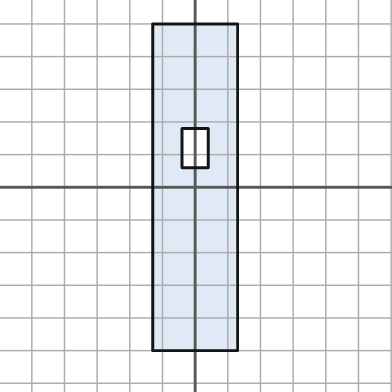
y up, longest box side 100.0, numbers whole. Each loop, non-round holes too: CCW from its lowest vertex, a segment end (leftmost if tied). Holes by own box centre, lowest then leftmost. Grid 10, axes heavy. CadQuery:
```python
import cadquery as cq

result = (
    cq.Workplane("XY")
    .moveTo(-13.0, -50.0)
    .lineTo(13.0, -50.0)
    .lineTo(13.0, 50.0)
    .lineTo(-13.0, 50.0)
    .close()
    .moveTo(-4.0, 6.0)
    .lineTo(4.0, 6.0)
    .lineTo(4.0, 18.0)
    .lineTo(-4.0, 18.0)
    .close()
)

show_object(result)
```